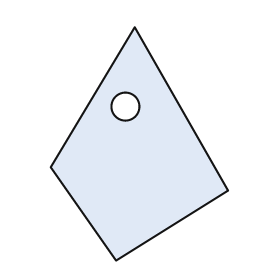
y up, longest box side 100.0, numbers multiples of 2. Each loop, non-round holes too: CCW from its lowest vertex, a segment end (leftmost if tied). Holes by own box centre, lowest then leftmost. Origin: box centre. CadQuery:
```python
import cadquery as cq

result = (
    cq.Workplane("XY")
    .moveTo(-10.0, -50.0)
    .lineTo(38.0, -20.0)
    .lineTo(-2.0, 50.0)
    .lineTo(-38.0, -10.0)
    .close()
    .moveTo(-6.0, 16.0)
    .circle(6.0)
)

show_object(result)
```